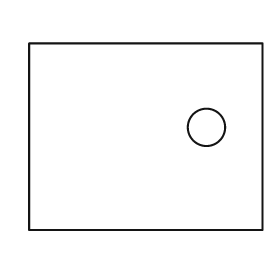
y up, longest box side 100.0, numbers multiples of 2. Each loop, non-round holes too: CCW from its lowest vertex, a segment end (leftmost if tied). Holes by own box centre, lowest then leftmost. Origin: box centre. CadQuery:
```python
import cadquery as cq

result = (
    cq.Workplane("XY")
    .moveTo(-50.0, -40.0)
    .lineTo(50.0, -40.0)
    .lineTo(50.0, 40.0)
    .lineTo(-50.0, 40.0)
    .close()
    .moveTo(26.0, 4.0)
    .circle(8.0)
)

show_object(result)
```